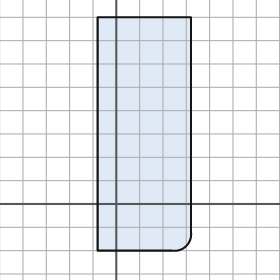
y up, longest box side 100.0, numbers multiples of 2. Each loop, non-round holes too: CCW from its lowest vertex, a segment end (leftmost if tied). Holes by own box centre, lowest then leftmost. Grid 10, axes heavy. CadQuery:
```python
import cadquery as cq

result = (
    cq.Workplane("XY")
    .moveTo(-8.0, -20.0)
    .lineTo(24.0, -20.0)
    .threePointArc((30.0, -18.0), (32.0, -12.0))
    .lineTo(32.0, 80.0)
    .lineTo(-8.0, 80.0)
    .close()
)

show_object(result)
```